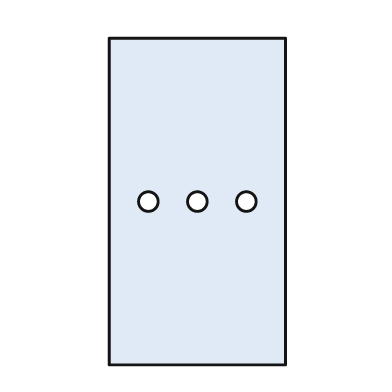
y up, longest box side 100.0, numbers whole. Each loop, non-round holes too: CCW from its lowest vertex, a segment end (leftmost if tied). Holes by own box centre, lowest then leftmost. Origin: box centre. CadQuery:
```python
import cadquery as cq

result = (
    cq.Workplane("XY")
    .moveTo(-27.0, -50.0)
    .lineTo(27.0, -50.0)
    .lineTo(27.0, 50.0)
    .lineTo(-27.0, 50.0)
    .close()
    .moveTo(-15.0, 0.0)
    .circle(3.0)
    .moveTo(0.0, 0.0)
    .circle(3.0)
    .moveTo(15.0, 0.0)
    .circle(3.0)
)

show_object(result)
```